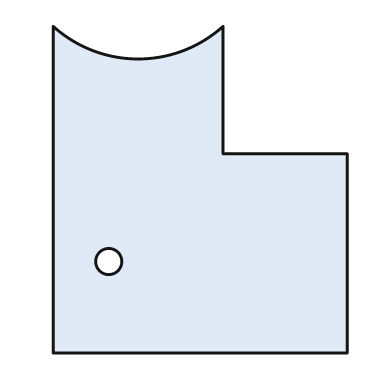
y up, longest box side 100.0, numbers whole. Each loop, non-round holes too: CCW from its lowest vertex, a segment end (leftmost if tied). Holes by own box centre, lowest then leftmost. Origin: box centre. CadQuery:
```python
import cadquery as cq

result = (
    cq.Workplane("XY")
    .moveTo(-45.0, -50.0)
    .lineTo(45.0, -50.0)
    .lineTo(45.0, 11.0)
    .lineTo(7.0, 11.0)
    .lineTo(7.0, 50.0)
    .threePointArc((-19.0, 40.0), (-45.0, 50.0))
    .close()
    .moveTo(-28.0, -22.0)
    .circle(4.0)
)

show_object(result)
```